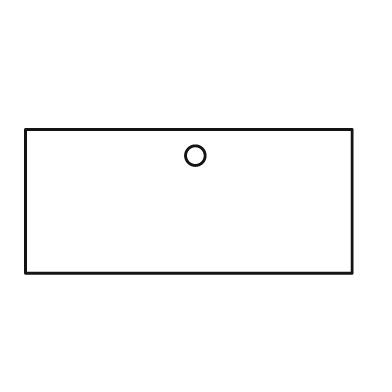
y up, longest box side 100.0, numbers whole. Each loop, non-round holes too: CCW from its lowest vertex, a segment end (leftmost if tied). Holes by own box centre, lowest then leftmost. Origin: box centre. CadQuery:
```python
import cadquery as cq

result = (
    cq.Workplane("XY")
    .moveTo(-50.0, -22.0)
    .lineTo(50.0, -22.0)
    .lineTo(50.0, 22.0)
    .lineTo(-50.0, 22.0)
    .close()
    .moveTo(2.0, 14.0)
    .circle(3.0)
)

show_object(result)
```